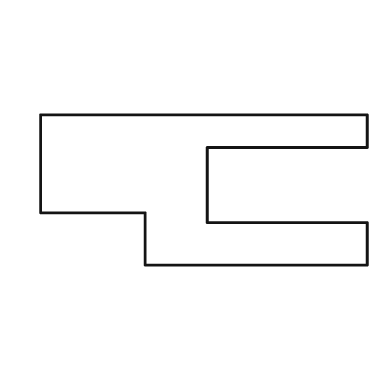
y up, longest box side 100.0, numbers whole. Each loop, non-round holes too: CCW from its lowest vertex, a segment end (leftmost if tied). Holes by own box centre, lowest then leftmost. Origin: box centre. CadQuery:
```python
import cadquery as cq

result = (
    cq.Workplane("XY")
    .moveTo(-18.0, -23.0)
    .lineTo(50.0, -23.0)
    .lineTo(50.0, -10.0)
    .lineTo(1.0, -10.0)
    .lineTo(1.0, 13.0)
    .lineTo(50.0, 13.0)
    .lineTo(50.0, 23.0)
    .lineTo(-50.0, 23.0)
    .lineTo(-50.0, -7.0)
    .lineTo(-18.0, -7.0)
    .close()
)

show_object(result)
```